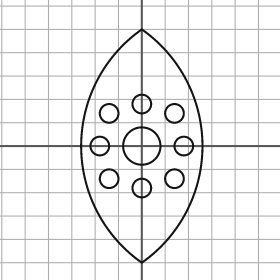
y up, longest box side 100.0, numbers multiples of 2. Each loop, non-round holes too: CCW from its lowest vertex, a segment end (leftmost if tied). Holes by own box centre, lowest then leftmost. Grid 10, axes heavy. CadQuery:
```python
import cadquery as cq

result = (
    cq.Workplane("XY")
    .moveTo(0.0, -50.0)
    .threePointArc((26.0, 0.0), (0.0, 50.0))
    .threePointArc((-26.0, 0.0), (0.0, -50.0))
    .close()
    .moveTo(0.0, -18.0)
    .circle(4.0)
    .moveTo(-14.0, -14.0)
    .circle(4.0)
    .moveTo(14.0, -14.0)
    .circle(4.0)
    .moveTo(-18.0, 0.0)
    .circle(4.0)
    .moveTo(0.0, 0.0)
    .circle(8.0)
    .moveTo(18.0, 0.0)
    .circle(4.0)
    .moveTo(-14.0, 14.0)
    .circle(4.0)
    .moveTo(14.0, 14.0)
    .circle(4.0)
    .moveTo(0.0, 18.0)
    .circle(4.0)
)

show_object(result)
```